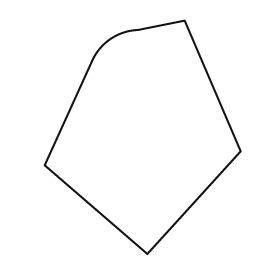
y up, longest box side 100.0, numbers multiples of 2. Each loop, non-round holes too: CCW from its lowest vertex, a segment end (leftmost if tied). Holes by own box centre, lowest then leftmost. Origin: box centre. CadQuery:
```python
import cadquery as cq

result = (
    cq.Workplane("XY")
    .moveTo(2.0, -50.0)
    .lineTo(42.0, -6.0)
    .lineTo(18.0, 50.0)
    .lineTo(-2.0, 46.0)
    .threePointArc((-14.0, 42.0), (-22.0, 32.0))
    .lineTo(-42.0, -12.0)
    .close()
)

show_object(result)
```